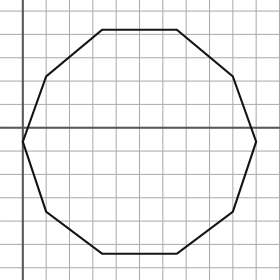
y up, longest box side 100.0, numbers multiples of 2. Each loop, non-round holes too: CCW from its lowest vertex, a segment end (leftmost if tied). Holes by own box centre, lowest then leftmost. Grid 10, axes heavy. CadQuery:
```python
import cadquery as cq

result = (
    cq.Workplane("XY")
    .moveTo(34.0, -54.0)
    .lineTo(66.0, -54.0)
    .lineTo(90.0, -36.0)
    .lineTo(100.0, -6.0)
    .lineTo(90.0, 22.0)
    .lineTo(66.0, 42.0)
    .lineTo(34.0, 42.0)
    .lineTo(10.0, 22.0)
    .lineTo(0.0, -6.0)
    .lineTo(10.0, -36.0)
    .close()
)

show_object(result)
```